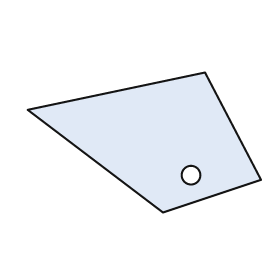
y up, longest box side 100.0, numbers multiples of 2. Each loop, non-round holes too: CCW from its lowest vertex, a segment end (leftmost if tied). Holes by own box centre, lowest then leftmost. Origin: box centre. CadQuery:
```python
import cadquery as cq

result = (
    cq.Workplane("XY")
    .moveTo(8.0, -30.0)
    .lineTo(50.0, -16.0)
    .lineTo(26.0, 30.0)
    .lineTo(-50.0, 14.0)
    .close()
    .moveTo(20.0, -14.0)
    .circle(4.0)
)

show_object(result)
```